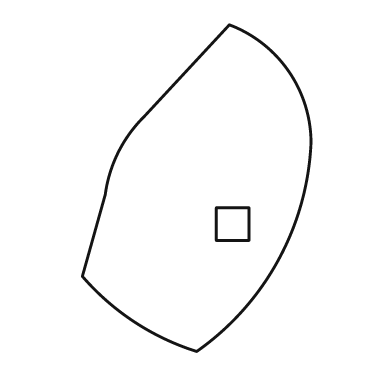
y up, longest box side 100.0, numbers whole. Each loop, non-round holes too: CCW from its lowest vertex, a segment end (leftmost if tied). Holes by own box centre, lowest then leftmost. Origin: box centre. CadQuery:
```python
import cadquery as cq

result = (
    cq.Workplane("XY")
    .moveTo(0.0, -50.0)
    .threePointArc((25.0, -22.0), (35.0, 14.0))
    .threePointArc((28.0, 36.0), (10.0, 50.0))
    .lineTo(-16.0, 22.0)
    .threePointArc((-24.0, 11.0), (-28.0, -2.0))
    .lineTo(-35.0, -27.0)
    .threePointArc((-19.0, -41.0), (0.0, -50.0))
    .close()
    .moveTo(6.0, -16.0)
    .lineTo(16.0, -16.0)
    .lineTo(16.0, -6.0)
    .lineTo(6.0, -6.0)
    .close()
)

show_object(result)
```